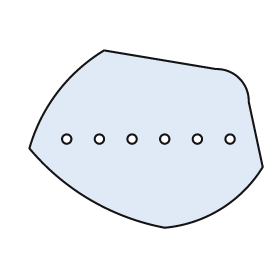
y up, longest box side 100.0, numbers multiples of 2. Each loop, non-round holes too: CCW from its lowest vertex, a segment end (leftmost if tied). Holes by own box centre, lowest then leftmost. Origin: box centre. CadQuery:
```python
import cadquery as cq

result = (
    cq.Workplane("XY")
    .moveTo(8.0, -38.0)
    .threePointArc((32.0, -30.0), (50.0, -12.0))
    .lineTo(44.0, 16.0)
    .threePointArc((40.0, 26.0), (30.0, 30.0))
    .lineTo(-18.0, 38.0)
    .threePointArc((-38.0, 20.0), (-50.0, -4.0))
    .threePointArc((-24.0, -26.0), (8.0, -38.0))
    .close()
    .moveTo(-34.0, 0.0)
    .circle(2.0)
    .moveTo(-20.0, 0.0)
    .circle(2.0)
    .moveTo(-6.0, 0.0)
    .circle(2.0)
    .moveTo(8.0, 0.0)
    .circle(2.0)
    .moveTo(22.0, 0.0)
    .circle(2.0)
    .moveTo(36.0, 0.0)
    .circle(2.0)
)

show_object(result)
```